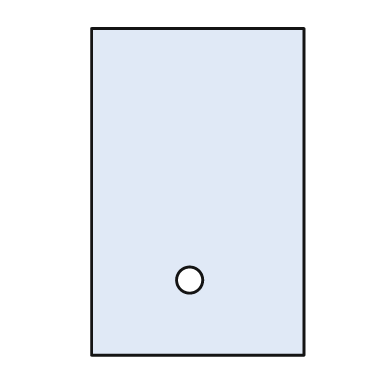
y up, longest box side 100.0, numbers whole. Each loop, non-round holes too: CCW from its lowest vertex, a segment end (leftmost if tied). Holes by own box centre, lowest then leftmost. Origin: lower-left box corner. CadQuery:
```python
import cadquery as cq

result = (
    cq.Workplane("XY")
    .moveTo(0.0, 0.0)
    .lineTo(65.0, 0.0)
    .lineTo(65.0, 100.0)
    .lineTo(0.0, 100.0)
    .close()
    .moveTo(30.0, 23.0)
    .circle(4.0)
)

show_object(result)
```